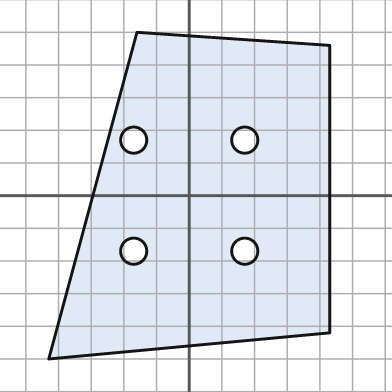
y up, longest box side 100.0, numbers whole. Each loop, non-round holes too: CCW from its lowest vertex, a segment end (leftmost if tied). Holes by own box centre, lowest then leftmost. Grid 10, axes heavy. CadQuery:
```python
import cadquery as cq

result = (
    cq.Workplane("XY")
    .moveTo(-43.0, -50.0)
    .lineTo(43.0, -42.0)
    .lineTo(43.0, 46.0)
    .lineTo(-16.0, 50.0)
    .close()
    .moveTo(-17.0, -17.0)
    .circle(4.0)
    .moveTo(17.0, -17.0)
    .circle(4.0)
    .moveTo(-17.0, 17.0)
    .circle(4.0)
    .moveTo(17.0, 17.0)
    .circle(4.0)
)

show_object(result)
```